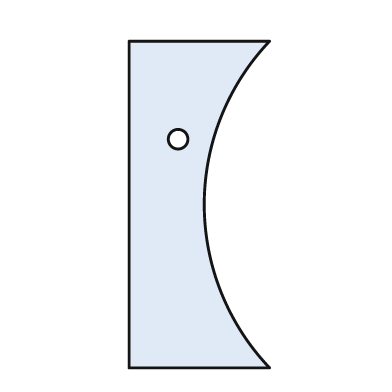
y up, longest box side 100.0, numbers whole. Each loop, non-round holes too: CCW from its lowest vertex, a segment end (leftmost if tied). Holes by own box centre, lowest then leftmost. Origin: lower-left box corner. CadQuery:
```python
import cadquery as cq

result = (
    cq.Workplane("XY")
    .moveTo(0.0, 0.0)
    .lineTo(43.0, 0.0)
    .threePointArc((23.0, 50.0), (43.0, 100.0))
    .lineTo(0.0, 100.0)
    .close()
    .moveTo(15.0, 70.0)
    .circle(3.0)
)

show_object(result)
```